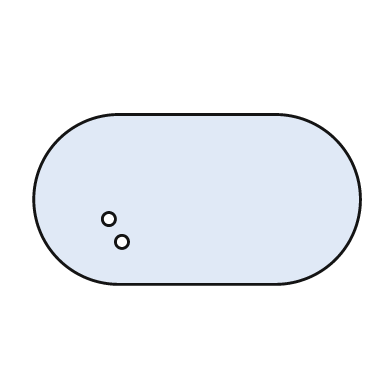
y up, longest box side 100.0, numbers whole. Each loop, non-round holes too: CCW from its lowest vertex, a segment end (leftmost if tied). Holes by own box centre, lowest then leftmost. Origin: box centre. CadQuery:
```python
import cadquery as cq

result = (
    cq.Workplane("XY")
    .moveTo(-24.0, -26.0)
    .lineTo(24.0, -26.0)
    .threePointArc((50.0, 0.0), (24.0, 26.0))
    .lineTo(-24.0, 26.0)
    .threePointArc((-50.0, 0.0), (-24.0, -26.0))
    .close()
    .moveTo(-23.0, -13.0)
    .circle(2.0)
    .moveTo(-27.0, -6.0)
    .circle(2.0)
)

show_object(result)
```